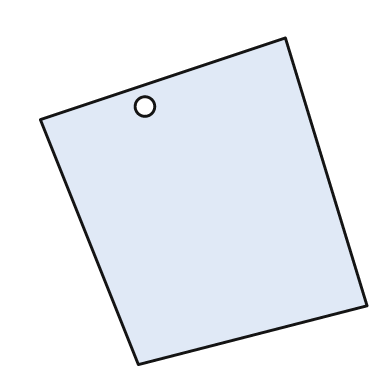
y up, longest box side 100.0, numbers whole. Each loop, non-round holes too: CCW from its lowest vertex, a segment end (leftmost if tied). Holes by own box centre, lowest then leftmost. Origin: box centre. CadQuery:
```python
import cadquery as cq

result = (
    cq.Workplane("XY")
    .moveTo(-20.0, -50.0)
    .lineTo(50.0, -32.0)
    .lineTo(25.0, 50.0)
    .lineTo(-50.0, 25.0)
    .close()
    .moveTo(-18.0, 29.0)
    .circle(3.0)
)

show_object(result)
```